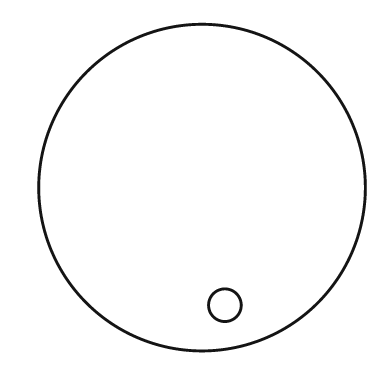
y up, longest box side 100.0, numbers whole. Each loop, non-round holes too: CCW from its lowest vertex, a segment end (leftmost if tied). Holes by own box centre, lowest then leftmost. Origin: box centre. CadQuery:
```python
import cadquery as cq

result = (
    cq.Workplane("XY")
    .moveTo(0.0, 0.0)
    .circle(50.0)
    .moveTo(7.0, -36.0)
    .circle(5.0)
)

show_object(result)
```